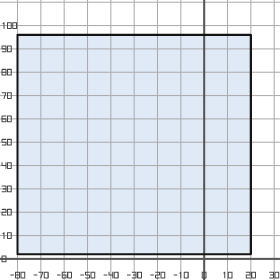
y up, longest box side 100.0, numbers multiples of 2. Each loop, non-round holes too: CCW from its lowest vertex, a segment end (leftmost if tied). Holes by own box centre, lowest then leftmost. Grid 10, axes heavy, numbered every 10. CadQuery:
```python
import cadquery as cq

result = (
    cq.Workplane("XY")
    .moveTo(-80.0, 2.0)
    .lineTo(20.0, 2.0)
    .lineTo(20.0, 96.0)
    .lineTo(-80.0, 96.0)
    .close()
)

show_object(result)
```